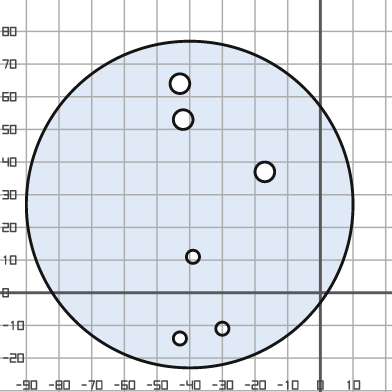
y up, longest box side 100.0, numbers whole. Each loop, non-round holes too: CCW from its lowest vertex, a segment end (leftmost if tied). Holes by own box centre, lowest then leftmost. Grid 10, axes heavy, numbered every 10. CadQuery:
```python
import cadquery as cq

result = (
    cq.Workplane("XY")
    .moveTo(-40.0, 27.0)
    .circle(50.0)
    .moveTo(-43.0, -14.0)
    .circle(2.0)
    .moveTo(-30.0, -11.0)
    .circle(2.0)
    .moveTo(-39.0, 11.0)
    .circle(2.0)
    .moveTo(-17.0, 37.0)
    .circle(3.0)
    .moveTo(-42.0, 53.0)
    .circle(3.0)
    .moveTo(-43.0, 64.0)
    .circle(3.0)
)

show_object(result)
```